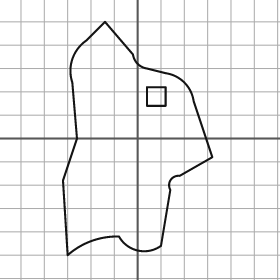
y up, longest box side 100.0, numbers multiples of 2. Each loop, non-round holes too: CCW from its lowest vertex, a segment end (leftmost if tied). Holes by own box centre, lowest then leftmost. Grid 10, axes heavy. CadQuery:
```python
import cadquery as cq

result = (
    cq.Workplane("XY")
    .moveTo(-30.0, -50.0)
    .threePointArc((-20.0, -44.0), (-8.0, -42.0))
    .threePointArc((0.0, -48.0), (10.0, -46.0))
    .lineTo(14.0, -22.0)
    .threePointArc((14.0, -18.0), (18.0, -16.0))
    .lineTo(32.0, -8.0)
    .lineTo(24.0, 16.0)
    .threePointArc((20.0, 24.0), (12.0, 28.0))
    .lineTo(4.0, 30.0)
    .threePointArc((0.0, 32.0), (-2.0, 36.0))
    .lineTo(-14.0, 50.0)
    .lineTo(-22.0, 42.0)
    .threePointArc((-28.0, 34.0), (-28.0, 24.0))
    .lineTo(-26.0, 0.0)
    .lineTo(-32.0, -18.0)
    .close()
    .moveTo(4.0, 14.0)
    .lineTo(12.0, 14.0)
    .lineTo(12.0, 22.0)
    .lineTo(4.0, 22.0)
    .close()
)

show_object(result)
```